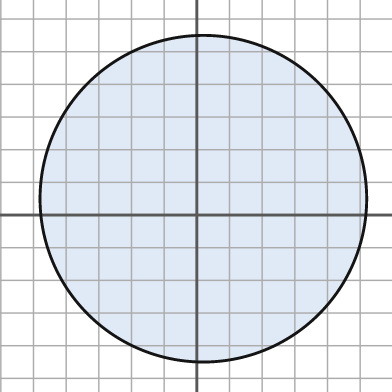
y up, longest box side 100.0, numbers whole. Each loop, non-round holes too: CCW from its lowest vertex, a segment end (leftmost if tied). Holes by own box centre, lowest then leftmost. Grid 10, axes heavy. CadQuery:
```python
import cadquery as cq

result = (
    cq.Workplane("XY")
    .moveTo(2.0, 5.0)
    .circle(50.0)
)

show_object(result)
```